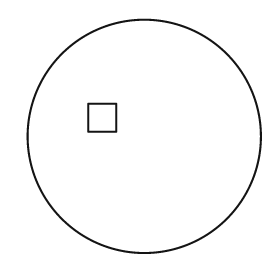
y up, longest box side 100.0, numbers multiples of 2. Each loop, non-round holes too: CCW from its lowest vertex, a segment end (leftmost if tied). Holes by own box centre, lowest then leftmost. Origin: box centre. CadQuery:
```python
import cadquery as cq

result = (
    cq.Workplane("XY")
    .moveTo(0.0, 0.0)
    .circle(50.0)
    .moveTo(-24.0, 2.0)
    .lineTo(-12.0, 2.0)
    .lineTo(-12.0, 14.0)
    .lineTo(-24.0, 14.0)
    .close()
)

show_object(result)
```